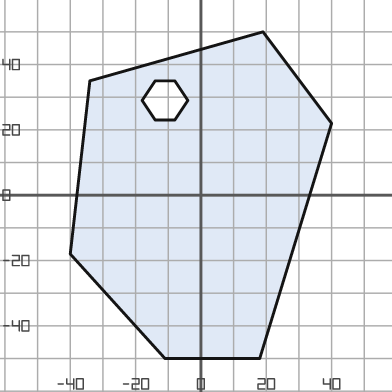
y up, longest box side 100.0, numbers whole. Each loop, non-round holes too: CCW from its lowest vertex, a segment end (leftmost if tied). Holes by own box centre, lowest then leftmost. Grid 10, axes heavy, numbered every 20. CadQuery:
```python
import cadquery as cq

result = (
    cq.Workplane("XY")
    .moveTo(-11.0, -50.0)
    .lineTo(18.0, -50.0)
    .lineTo(40.0, 22.0)
    .lineTo(19.0, 50.0)
    .lineTo(-34.0, 35.0)
    .lineTo(-40.0, -18.0)
    .close()
    .moveTo(-14.0, 23.0)
    .lineTo(-8.0, 23.0)
    .lineTo(-4.0, 29.0)
    .lineTo(-8.0, 35.0)
    .lineTo(-14.0, 35.0)
    .lineTo(-18.0, 29.0)
    .close()
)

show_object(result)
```